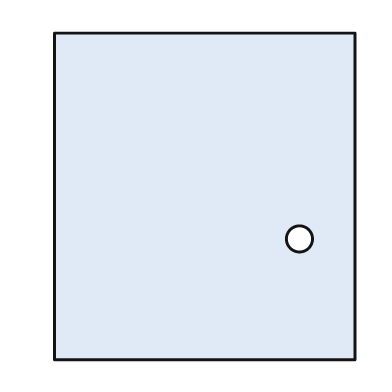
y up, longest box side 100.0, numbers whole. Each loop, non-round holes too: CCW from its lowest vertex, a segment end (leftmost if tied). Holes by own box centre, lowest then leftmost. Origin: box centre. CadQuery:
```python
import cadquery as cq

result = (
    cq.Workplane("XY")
    .moveTo(-46.0, -50.0)
    .lineTo(46.0, -50.0)
    .lineTo(46.0, 50.0)
    .lineTo(-46.0, 50.0)
    .close()
    .moveTo(29.0, -13.0)
    .circle(4.0)
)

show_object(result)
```